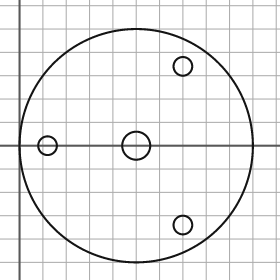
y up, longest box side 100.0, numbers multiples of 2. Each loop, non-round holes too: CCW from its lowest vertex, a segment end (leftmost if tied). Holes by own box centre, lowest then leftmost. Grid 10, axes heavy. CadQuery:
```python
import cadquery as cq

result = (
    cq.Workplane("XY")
    .moveTo(50.0, 0.0)
    .circle(50.0)
    .moveTo(70.0, -34.0)
    .circle(4.0)
    .moveTo(12.0, 0.0)
    .circle(4.0)
    .moveTo(50.0, 0.0)
    .circle(6.0)
    .moveTo(70.0, 34.0)
    .circle(4.0)
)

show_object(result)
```